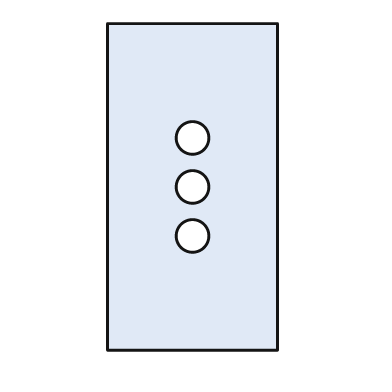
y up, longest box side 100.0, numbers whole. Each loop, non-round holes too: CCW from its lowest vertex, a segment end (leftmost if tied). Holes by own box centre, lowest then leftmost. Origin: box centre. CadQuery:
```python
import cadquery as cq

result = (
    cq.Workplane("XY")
    .moveTo(-26.0, -50.0)
    .lineTo(26.0, -50.0)
    .lineTo(26.0, 50.0)
    .lineTo(-26.0, 50.0)
    .close()
    .moveTo(0.0, -15.0)
    .circle(5.0)
    .moveTo(0.0, 0.0)
    .circle(5.0)
    .moveTo(0.0, 15.0)
    .circle(5.0)
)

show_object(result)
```